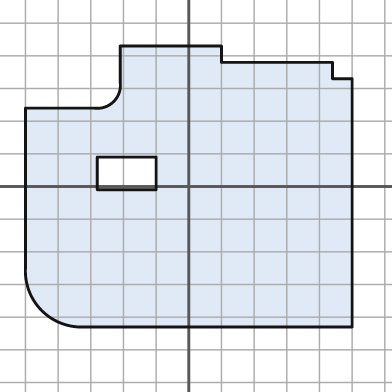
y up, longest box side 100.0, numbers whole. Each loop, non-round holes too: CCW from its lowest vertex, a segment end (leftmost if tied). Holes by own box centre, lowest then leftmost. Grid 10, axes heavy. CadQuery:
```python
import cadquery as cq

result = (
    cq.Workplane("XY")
    .moveTo(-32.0, -43.0)
    .lineTo(50.0, -43.0)
    .lineTo(50.0, 33.0)
    .lineTo(44.0, 33.0)
    .lineTo(44.0, 38.0)
    .lineTo(10.0, 38.0)
    .lineTo(10.0, 43.0)
    .lineTo(-21.0, 43.0)
    .lineTo(-21.0, 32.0)
    .threePointArc((-23.0, 26.0), (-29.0, 24.0))
    .lineTo(-50.0, 24.0)
    .lineTo(-50.0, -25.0)
    .threePointArc((-45.0, -38.0), (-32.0, -43.0))
    .close()
    .moveTo(-28.0, -1.0)
    .lineTo(-10.0, -1.0)
    .lineTo(-10.0, 9.0)
    .lineTo(-28.0, 9.0)
    .close()
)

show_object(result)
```